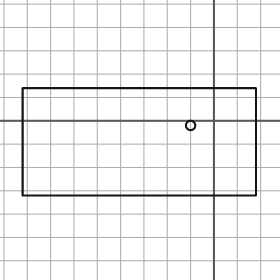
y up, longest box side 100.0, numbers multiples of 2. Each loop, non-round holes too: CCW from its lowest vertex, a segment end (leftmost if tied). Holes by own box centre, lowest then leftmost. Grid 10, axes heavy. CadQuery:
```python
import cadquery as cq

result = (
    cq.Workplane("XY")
    .moveTo(-82.0, -32.0)
    .lineTo(18.0, -32.0)
    .lineTo(18.0, 14.0)
    .lineTo(-82.0, 14.0)
    .close()
    .moveTo(-10.0, -2.0)
    .circle(2.0)
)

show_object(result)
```